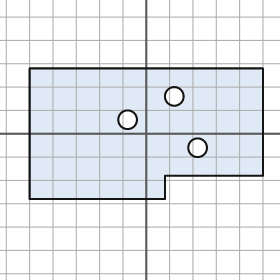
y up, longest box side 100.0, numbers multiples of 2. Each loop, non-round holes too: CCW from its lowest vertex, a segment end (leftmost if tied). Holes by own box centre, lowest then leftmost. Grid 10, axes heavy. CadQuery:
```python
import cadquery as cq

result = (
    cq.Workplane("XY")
    .moveTo(-50.0, -28.0)
    .lineTo(8.0, -28.0)
    .lineTo(8.0, -18.0)
    .lineTo(50.0, -18.0)
    .lineTo(50.0, 28.0)
    .lineTo(-50.0, 28.0)
    .close()
    .moveTo(22.0, -6.0)
    .circle(4.0)
    .moveTo(-8.0, 6.0)
    .circle(4.0)
    .moveTo(12.0, 16.0)
    .circle(4.0)
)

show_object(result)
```